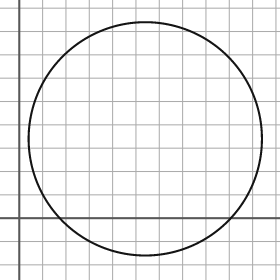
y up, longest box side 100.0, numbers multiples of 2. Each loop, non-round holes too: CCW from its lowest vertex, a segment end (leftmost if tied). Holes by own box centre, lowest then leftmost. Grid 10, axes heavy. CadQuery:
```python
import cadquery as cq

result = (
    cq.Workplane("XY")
    .moveTo(54.0, 34.0)
    .circle(50.0)
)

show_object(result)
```